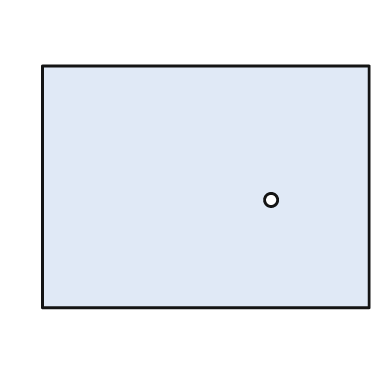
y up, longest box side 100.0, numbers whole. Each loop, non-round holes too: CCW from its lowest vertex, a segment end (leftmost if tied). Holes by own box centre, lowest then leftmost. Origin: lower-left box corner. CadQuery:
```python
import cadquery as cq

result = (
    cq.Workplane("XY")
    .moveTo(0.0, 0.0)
    .lineTo(100.0, 0.0)
    .lineTo(100.0, 74.0)
    .lineTo(0.0, 74.0)
    .close()
    .moveTo(70.0, 33.0)
    .circle(2.0)
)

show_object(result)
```